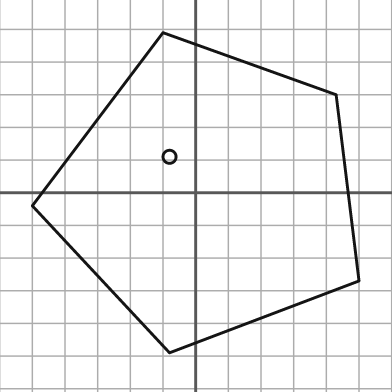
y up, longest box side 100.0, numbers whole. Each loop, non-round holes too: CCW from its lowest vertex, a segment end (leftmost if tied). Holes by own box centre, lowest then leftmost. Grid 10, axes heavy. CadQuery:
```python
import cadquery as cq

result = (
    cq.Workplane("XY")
    .moveTo(-8.0, -49.0)
    .lineTo(50.0, -27.0)
    .lineTo(43.0, 30.0)
    .lineTo(-10.0, 49.0)
    .lineTo(-50.0, -4.0)
    .close()
    .moveTo(-8.0, 11.0)
    .circle(2.0)
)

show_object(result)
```